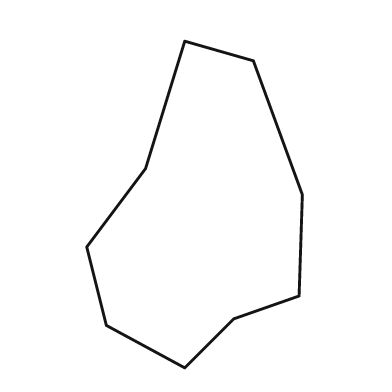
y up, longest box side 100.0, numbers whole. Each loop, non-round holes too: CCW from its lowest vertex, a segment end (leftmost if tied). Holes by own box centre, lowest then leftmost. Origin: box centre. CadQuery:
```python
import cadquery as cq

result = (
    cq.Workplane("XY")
    .moveTo(-3.0, -50.0)
    .lineTo(12.0, -35.0)
    .lineTo(32.0, -28.0)
    .lineTo(33.0, 3.0)
    .lineTo(18.0, 44.0)
    .lineTo(-3.0, 50.0)
    .lineTo(-15.0, 11.0)
    .lineTo(-33.0, -13.0)
    .lineTo(-27.0, -37.0)
    .close()
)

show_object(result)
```